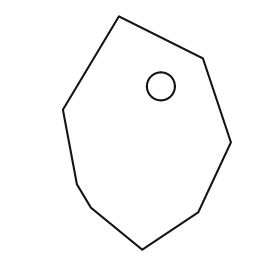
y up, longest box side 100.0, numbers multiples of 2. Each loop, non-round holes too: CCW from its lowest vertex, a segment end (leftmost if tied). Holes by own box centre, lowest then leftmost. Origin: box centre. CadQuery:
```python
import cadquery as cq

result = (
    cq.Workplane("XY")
    .moveTo(-2.0, -50.0)
    .lineTo(22.0, -34.0)
    .lineTo(36.0, -4.0)
    .lineTo(24.0, 32.0)
    .lineTo(-12.0, 50.0)
    .lineTo(-36.0, 10.0)
    .lineTo(-30.0, -22.0)
    .lineTo(-24.0, -32.0)
    .close()
    .moveTo(6.0, 20.0)
    .circle(6.0)
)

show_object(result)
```